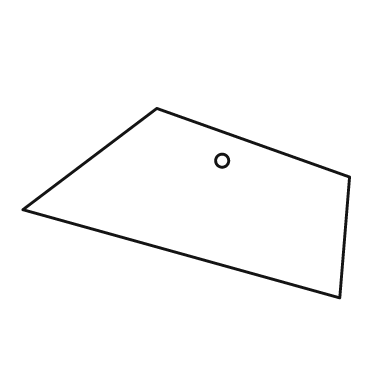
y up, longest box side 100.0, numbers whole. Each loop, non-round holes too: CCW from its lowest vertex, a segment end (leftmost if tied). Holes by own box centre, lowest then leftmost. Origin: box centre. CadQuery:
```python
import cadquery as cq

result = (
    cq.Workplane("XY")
    .moveTo(47.0, -29.0)
    .lineTo(50.0, 8.0)
    .lineTo(-9.0, 29.0)
    .lineTo(-50.0, -2.0)
    .close()
    .moveTo(11.0, 13.0)
    .circle(2.0)
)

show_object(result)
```